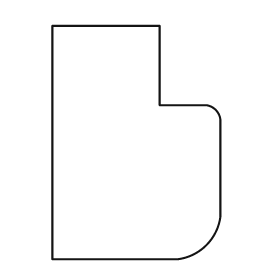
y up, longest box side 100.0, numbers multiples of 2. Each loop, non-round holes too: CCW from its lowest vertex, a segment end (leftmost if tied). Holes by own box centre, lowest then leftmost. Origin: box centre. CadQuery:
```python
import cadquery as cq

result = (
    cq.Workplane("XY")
    .moveTo(-36.0, -50.0)
    .lineTo(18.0, -50.0)
    .threePointArc((30.0, -44.0), (36.0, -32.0))
    .lineTo(36.0, 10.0)
    .threePointArc((34.0, 14.0), (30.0, 16.0))
    .lineTo(10.0, 16.0)
    .lineTo(10.0, 50.0)
    .lineTo(-36.0, 50.0)
    .close()
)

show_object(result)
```